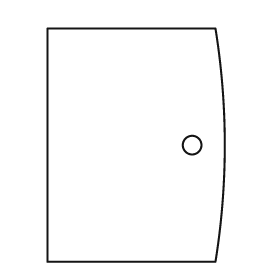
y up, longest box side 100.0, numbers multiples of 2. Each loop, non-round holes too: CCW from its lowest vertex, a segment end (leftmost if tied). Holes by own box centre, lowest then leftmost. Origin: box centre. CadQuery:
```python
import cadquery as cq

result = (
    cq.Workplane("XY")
    .moveTo(-38.0, -50.0)
    .lineTo(34.0, -50.0)
    .threePointArc((38.0, 0.0), (34.0, 50.0))
    .lineTo(-38.0, 50.0)
    .close()
    .moveTo(24.0, 0.0)
    .circle(4.0)
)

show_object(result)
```